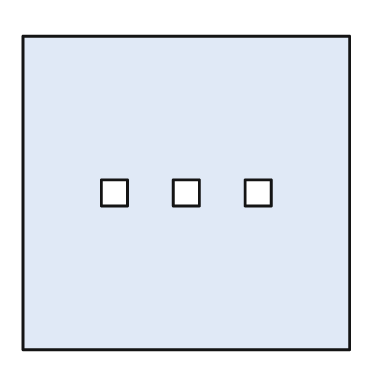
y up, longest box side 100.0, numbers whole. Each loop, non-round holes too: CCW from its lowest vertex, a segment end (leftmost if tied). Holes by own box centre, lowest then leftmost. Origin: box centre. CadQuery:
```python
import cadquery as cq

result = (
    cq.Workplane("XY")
    .moveTo(-50.0, -48.0)
    .lineTo(50.0, -48.0)
    .lineTo(50.0, 48.0)
    .lineTo(-50.0, 48.0)
    .close()
    .moveTo(-26.0, -4.0)
    .lineTo(-18.0, -4.0)
    .lineTo(-18.0, 4.0)
    .lineTo(-26.0, 4.0)
    .close()
    .moveTo(-4.0, -4.0)
    .lineTo(4.0, -4.0)
    .lineTo(4.0, 4.0)
    .lineTo(-4.0, 4.0)
    .close()
    .moveTo(18.0, -4.0)
    .lineTo(26.0, -4.0)
    .lineTo(26.0, 4.0)
    .lineTo(18.0, 4.0)
    .close()
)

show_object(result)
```